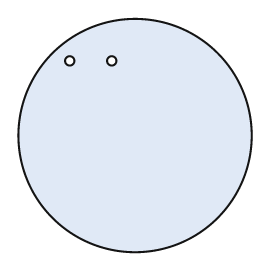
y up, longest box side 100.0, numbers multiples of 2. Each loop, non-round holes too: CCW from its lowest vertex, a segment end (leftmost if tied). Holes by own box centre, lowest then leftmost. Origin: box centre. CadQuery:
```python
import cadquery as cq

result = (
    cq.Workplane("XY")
    .moveTo(0.0, 0.0)
    .circle(50.0)
    .moveTo(-28.0, 32.0)
    .circle(2.0)
    .moveTo(-10.0, 32.0)
    .circle(2.0)
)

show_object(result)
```